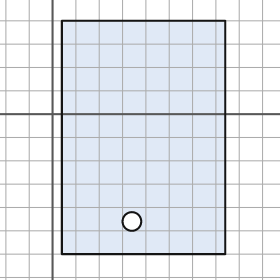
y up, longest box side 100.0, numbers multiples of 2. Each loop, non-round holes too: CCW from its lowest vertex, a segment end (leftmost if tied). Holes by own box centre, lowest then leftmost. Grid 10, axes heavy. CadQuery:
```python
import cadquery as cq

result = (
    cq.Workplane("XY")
    .moveTo(4.0, -60.0)
    .lineTo(74.0, -60.0)
    .lineTo(74.0, 40.0)
    .lineTo(4.0, 40.0)
    .close()
    .moveTo(34.0, -46.0)
    .circle(4.0)
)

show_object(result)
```